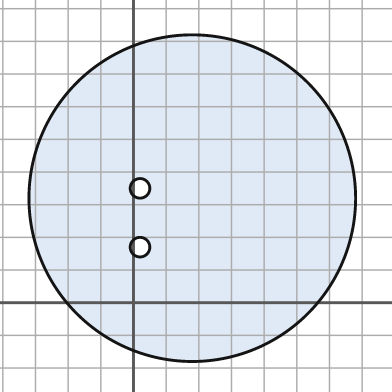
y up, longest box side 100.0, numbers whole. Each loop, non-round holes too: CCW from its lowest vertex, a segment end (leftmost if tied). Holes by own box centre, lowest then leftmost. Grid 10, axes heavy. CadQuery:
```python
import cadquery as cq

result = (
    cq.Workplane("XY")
    .moveTo(18.0, 32.0)
    .circle(50.0)
    .moveTo(2.0, 17.0)
    .circle(3.0)
    .moveTo(2.0, 35.0)
    .circle(3.0)
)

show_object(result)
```